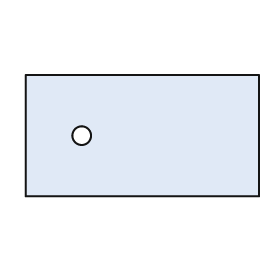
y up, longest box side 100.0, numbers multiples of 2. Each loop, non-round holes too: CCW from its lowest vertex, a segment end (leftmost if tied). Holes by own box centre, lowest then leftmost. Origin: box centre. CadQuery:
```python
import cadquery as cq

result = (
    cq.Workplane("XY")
    .moveTo(-50.0, -26.0)
    .lineTo(50.0, -26.0)
    .lineTo(50.0, 26.0)
    .lineTo(-50.0, 26.0)
    .close()
    .moveTo(-26.0, 0.0)
    .circle(4.0)
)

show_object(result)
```